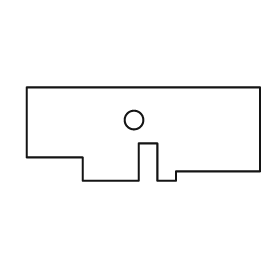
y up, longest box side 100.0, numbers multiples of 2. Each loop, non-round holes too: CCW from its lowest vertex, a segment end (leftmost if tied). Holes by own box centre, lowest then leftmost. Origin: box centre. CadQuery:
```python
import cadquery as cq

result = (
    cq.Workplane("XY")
    .moveTo(-26.0, -20.0)
    .lineTo(-2.0, -20.0)
    .lineTo(-2.0, -4.0)
    .lineTo(6.0, -4.0)
    .lineTo(6.0, -20.0)
    .lineTo(14.0, -20.0)
    .lineTo(14.0, -16.0)
    .lineTo(50.0, -16.0)
    .lineTo(50.0, 20.0)
    .lineTo(-50.0, 20.0)
    .lineTo(-50.0, -10.0)
    .lineTo(-26.0, -10.0)
    .close()
    .moveTo(-4.0, 6.0)
    .circle(4.0)
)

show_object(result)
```